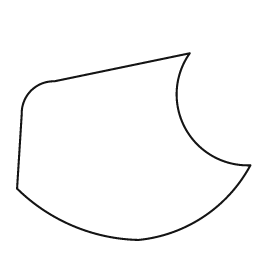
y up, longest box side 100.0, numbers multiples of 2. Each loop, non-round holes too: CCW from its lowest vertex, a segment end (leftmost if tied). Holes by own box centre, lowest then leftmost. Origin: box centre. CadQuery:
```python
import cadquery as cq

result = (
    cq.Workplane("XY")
    .moveTo(2.0, -40.0)
    .threePointArc((30.0, -30.0), (50.0, -8.0))
    .threePointArc((22.0, 8.0), (24.0, 40.0))
    .lineTo(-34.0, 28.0)
    .threePointArc((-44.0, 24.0), (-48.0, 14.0))
    .lineTo(-50.0, -18.0)
    .threePointArc((-26.0, -34.0), (2.0, -40.0))
    .close()
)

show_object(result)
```